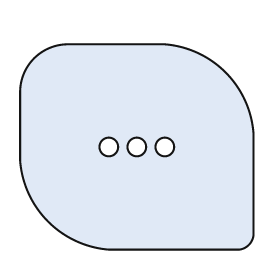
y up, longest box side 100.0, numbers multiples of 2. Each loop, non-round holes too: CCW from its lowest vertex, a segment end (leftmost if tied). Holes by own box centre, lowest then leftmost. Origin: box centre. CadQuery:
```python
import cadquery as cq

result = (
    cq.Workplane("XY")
    .moveTo(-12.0, -44.0)
    .lineTo(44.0, -44.0)
    .threePointArc((48.0, -42.0), (50.0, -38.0))
    .lineTo(50.0, 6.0)
    .threePointArc((38.0, 32.0), (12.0, 44.0))
    .lineTo(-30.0, 44.0)
    .threePointArc((-44.0, 38.0), (-50.0, 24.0))
    .lineTo(-50.0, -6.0)
    .threePointArc((-38.0, -32.0), (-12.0, -44.0))
    .close()
    .moveTo(-12.0, 0.0)
    .circle(4.0)
    .moveTo(0.0, 0.0)
    .circle(4.0)
    .moveTo(12.0, 0.0)
    .circle(4.0)
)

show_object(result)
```